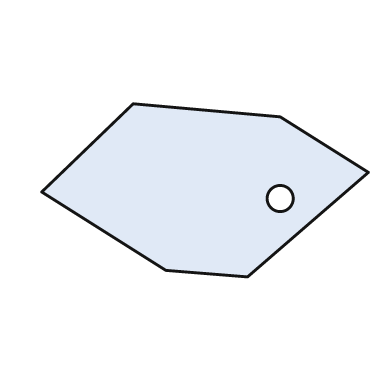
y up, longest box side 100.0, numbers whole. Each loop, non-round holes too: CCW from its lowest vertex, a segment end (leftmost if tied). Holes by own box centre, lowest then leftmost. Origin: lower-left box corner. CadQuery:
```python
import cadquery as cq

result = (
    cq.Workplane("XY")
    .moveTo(63.0, 0.0)
    .lineTo(100.0, 32.0)
    .lineTo(73.0, 49.0)
    .lineTo(28.0, 53.0)
    .lineTo(0.0, 26.0)
    .lineTo(38.0, 2.0)
    .close()
    .moveTo(73.0, 24.0)
    .circle(4.0)
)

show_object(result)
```